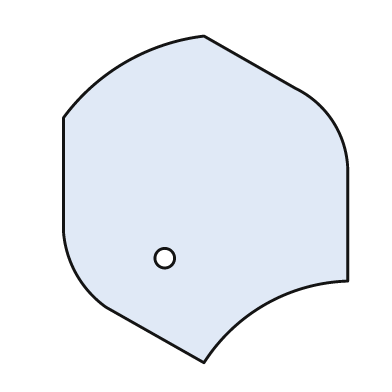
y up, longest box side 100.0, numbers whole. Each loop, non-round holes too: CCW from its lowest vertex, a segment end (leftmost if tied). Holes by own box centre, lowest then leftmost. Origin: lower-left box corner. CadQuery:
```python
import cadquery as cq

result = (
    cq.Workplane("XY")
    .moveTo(43.0, 0.0)
    .threePointArc((62.0, 18.0), (87.0, 25.0))
    .lineTo(87.0, 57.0)
    .threePointArc((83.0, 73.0), (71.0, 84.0))
    .lineTo(43.0, 100.0)
    .threePointArc((19.0, 92.0), (0.0, 75.0))
    .lineTo(0.0, 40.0)
    .threePointArc((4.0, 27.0), (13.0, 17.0))
    .close()
    .moveTo(31.0, 32.0)
    .circle(3.0)
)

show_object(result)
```